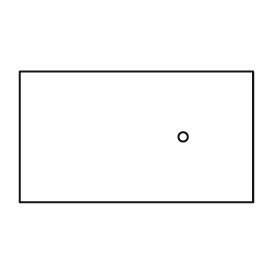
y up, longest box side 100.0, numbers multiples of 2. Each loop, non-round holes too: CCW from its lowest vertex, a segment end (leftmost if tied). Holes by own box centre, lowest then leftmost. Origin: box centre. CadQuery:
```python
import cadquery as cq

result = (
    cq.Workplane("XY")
    .moveTo(-50.0, -28.0)
    .lineTo(50.0, -28.0)
    .lineTo(50.0, 28.0)
    .lineTo(-50.0, 28.0)
    .close()
    .moveTo(20.0, 0.0)
    .circle(2.0)
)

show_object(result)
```